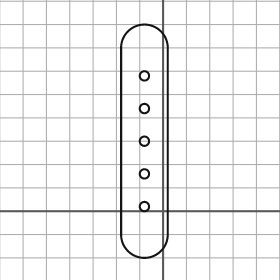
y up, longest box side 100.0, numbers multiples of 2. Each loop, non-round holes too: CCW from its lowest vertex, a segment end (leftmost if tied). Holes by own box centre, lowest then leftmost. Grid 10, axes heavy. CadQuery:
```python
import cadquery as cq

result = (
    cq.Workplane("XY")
    .moveTo(-18.0, -10.0)
    .threePointArc((-8.0, -20.0), (2.0, -10.0))
    .lineTo(2.0, 70.0)
    .threePointArc((-8.0, 80.0), (-18.0, 70.0))
    .close()
    .moveTo(-8.0, 2.0)
    .circle(2.0)
    .moveTo(-8.0, 16.0)
    .circle(2.0)
    .moveTo(-8.0, 30.0)
    .circle(2.0)
    .moveTo(-8.0, 44.0)
    .circle(2.0)
    .moveTo(-8.0, 58.0)
    .circle(2.0)
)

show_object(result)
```